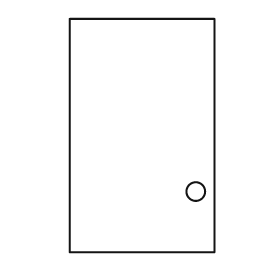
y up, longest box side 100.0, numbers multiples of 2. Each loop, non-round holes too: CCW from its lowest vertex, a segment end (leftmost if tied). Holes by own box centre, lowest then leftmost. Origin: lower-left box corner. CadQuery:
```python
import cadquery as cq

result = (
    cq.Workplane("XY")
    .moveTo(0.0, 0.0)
    .lineTo(62.0, 0.0)
    .lineTo(62.0, 100.0)
    .lineTo(0.0, 100.0)
    .close()
    .moveTo(54.0, 26.0)
    .circle(4.0)
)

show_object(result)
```